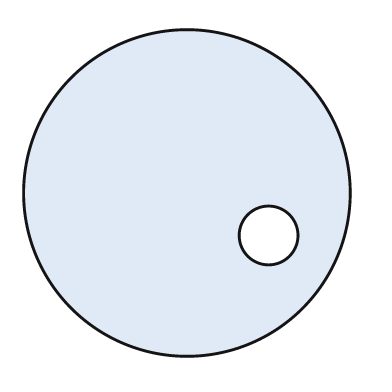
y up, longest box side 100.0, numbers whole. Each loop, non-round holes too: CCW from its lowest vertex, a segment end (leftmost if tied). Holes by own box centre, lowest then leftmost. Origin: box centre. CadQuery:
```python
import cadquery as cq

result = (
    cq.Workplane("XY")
    .moveTo(0.0, 0.0)
    .circle(50.0)
    .moveTo(25.0, -13.0)
    .circle(9.0)
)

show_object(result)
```